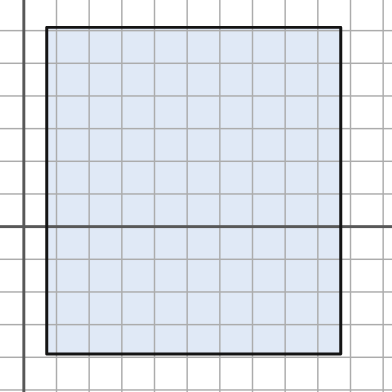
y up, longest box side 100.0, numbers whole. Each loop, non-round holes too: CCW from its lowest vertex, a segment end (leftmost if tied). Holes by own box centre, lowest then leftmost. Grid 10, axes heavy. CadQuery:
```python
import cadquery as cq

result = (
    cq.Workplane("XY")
    .moveTo(7.0, -39.0)
    .lineTo(97.0, -39.0)
    .lineTo(97.0, 61.0)
    .lineTo(7.0, 61.0)
    .close()
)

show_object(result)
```